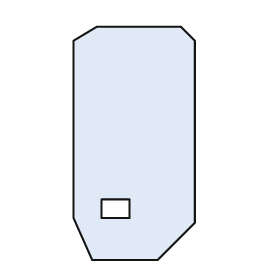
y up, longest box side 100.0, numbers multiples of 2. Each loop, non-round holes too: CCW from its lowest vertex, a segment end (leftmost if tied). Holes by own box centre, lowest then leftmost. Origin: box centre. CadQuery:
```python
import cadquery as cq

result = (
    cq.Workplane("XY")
    .moveTo(-18.0, -50.0)
    .lineTo(10.0, -50.0)
    .lineTo(26.0, -34.0)
    .lineTo(26.0, 44.0)
    .lineTo(20.0, 50.0)
    .lineTo(-16.0, 50.0)
    .lineTo(-26.0, 44.0)
    .lineTo(-26.0, -32.0)
    .close()
    .moveTo(-14.0, -32.0)
    .lineTo(-2.0, -32.0)
    .lineTo(-2.0, -24.0)
    .lineTo(-14.0, -24.0)
    .close()
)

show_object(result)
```